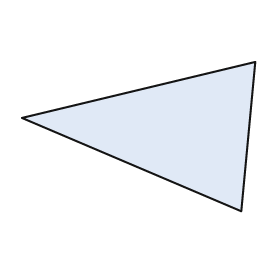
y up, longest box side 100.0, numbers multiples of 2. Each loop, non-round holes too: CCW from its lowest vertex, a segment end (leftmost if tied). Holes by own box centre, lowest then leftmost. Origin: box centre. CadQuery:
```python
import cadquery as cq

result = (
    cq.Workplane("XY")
    .moveTo(44.0, -32.0)
    .lineTo(50.0, 32.0)
    .lineTo(-50.0, 8.0)
    .close()
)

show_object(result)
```